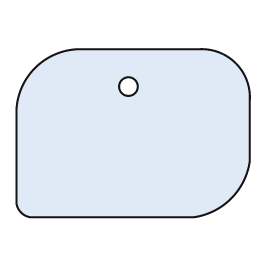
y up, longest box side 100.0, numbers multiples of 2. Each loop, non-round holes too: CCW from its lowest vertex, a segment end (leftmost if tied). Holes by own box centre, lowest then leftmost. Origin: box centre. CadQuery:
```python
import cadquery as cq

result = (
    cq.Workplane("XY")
    .moveTo(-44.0, -36.0)
    .lineTo(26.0, -36.0)
    .threePointArc((42.0, -28.0), (50.0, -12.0))
    .lineTo(50.0, 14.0)
    .threePointArc((44.0, 30.0), (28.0, 36.0))
    .lineTo(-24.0, 36.0)
    .threePointArc((-42.0, 28.0), (-50.0, 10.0))
    .lineTo(-50.0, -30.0)
    .threePointArc((-48.0, -34.0), (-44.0, -36.0))
    .close()
    .moveTo(-2.0, 20.0)
    .circle(4.0)
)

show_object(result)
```